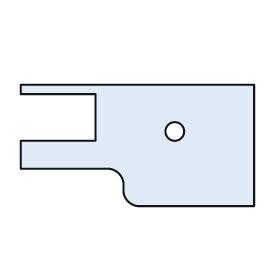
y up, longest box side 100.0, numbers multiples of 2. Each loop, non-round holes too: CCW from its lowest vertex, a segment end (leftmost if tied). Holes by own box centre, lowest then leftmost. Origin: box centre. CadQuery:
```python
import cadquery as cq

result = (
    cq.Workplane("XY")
    .moveTo(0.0, -26.0)
    .lineTo(50.0, -26.0)
    .lineTo(50.0, 26.0)
    .lineTo(-50.0, 26.0)
    .lineTo(-50.0, 22.0)
    .lineTo(-18.0, 22.0)
    .lineTo(-18.0, 2.0)
    .lineTo(-50.0, 2.0)
    .lineTo(-50.0, -10.0)
    .lineTo(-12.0, -10.0)
    .threePointArc((-8.0, -12.0), (-6.0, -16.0))
    .lineTo(-6.0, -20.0)
    .threePointArc((-4.0, -24.0), (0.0, -26.0))
    .close()
    .moveTo(16.0, 6.0)
    .circle(4.0)
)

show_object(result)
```